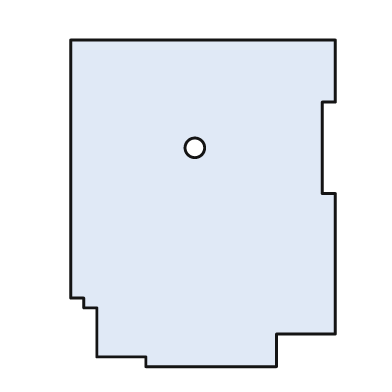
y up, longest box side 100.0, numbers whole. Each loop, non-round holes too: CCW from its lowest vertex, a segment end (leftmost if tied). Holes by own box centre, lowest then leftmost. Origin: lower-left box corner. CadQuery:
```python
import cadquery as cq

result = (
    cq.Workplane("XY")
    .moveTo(23.0, 0.0)
    .lineTo(63.0, 0.0)
    .lineTo(63.0, 10.0)
    .lineTo(81.0, 10.0)
    .lineTo(81.0, 53.0)
    .lineTo(77.0, 53.0)
    .lineTo(77.0, 81.0)
    .lineTo(81.0, 81.0)
    .lineTo(81.0, 100.0)
    .lineTo(0.0, 100.0)
    .lineTo(0.0, 21.0)
    .lineTo(4.0, 21.0)
    .lineTo(4.0, 18.0)
    .lineTo(8.0, 18.0)
    .lineTo(8.0, 3.0)
    .lineTo(23.0, 3.0)
    .close()
    .moveTo(38.0, 67.0)
    .circle(3.0)
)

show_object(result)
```